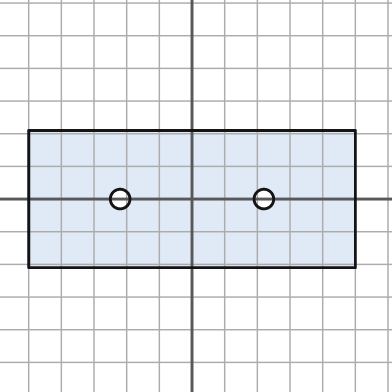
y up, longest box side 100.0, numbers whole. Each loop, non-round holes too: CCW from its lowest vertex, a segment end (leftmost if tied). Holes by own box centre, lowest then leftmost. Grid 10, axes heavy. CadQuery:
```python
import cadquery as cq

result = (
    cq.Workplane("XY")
    .moveTo(-50.0, -21.0)
    .lineTo(50.0, -21.0)
    .lineTo(50.0, 21.0)
    .lineTo(-50.0, 21.0)
    .close()
    .moveTo(-22.0, 0.0)
    .circle(3.0)
    .moveTo(22.0, 0.0)
    .circle(3.0)
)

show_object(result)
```